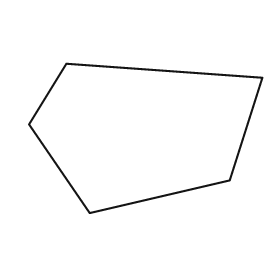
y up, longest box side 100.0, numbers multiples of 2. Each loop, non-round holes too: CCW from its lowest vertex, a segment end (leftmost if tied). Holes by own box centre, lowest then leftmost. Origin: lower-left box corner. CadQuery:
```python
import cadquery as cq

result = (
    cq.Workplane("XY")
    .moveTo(26.0, 0.0)
    .lineTo(86.0, 14.0)
    .lineTo(100.0, 58.0)
    .lineTo(16.0, 64.0)
    .lineTo(0.0, 38.0)
    .close()
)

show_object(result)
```